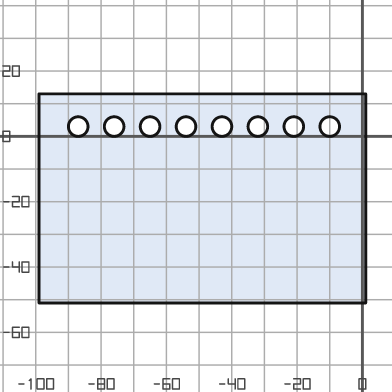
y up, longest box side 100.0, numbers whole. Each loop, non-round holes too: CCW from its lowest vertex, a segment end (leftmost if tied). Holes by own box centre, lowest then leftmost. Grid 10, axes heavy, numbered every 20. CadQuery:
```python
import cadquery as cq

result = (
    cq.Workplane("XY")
    .moveTo(-99.0, -51.0)
    .lineTo(1.0, -51.0)
    .lineTo(1.0, 13.0)
    .lineTo(-99.0, 13.0)
    .close()
    .moveTo(-87.0, 3.0)
    .circle(3.0)
    .moveTo(-76.0, 3.0)
    .circle(3.0)
    .moveTo(-65.0, 3.0)
    .circle(3.0)
    .moveTo(-54.0, 3.0)
    .circle(3.0)
    .moveTo(-43.0, 3.0)
    .circle(3.0)
    .moveTo(-32.0, 3.0)
    .circle(3.0)
    .moveTo(-21.0, 3.0)
    .circle(3.0)
    .moveTo(-10.0, 3.0)
    .circle(3.0)
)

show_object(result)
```